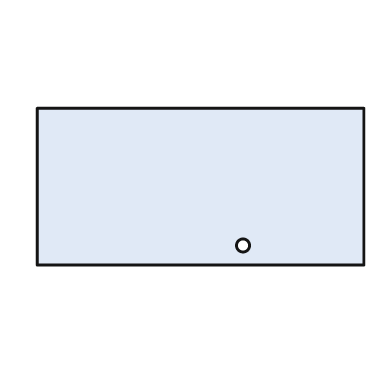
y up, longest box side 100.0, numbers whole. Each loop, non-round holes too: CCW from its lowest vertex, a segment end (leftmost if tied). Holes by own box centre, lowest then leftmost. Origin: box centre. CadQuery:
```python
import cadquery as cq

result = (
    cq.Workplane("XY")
    .moveTo(-50.0, -24.0)
    .lineTo(50.0, -24.0)
    .lineTo(50.0, 24.0)
    .lineTo(-50.0, 24.0)
    .close()
    .moveTo(13.0, -18.0)
    .circle(2.0)
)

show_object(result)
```